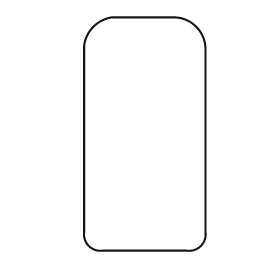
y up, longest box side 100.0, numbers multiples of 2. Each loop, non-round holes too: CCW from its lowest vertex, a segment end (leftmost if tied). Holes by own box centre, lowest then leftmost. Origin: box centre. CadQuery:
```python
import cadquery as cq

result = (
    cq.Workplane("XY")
    .moveTo(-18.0, -50.0)
    .lineTo(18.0, -50.0)
    .threePointArc((24.0, -48.0), (26.0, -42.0))
    .lineTo(26.0, 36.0)
    .threePointArc((22.0, 46.0), (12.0, 50.0))
    .lineTo(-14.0, 50.0)
    .threePointArc((-22.0, 46.0), (-26.0, 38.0))
    .lineTo(-26.0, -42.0)
    .threePointArc((-24.0, -48.0), (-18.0, -50.0))
    .close()
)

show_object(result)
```